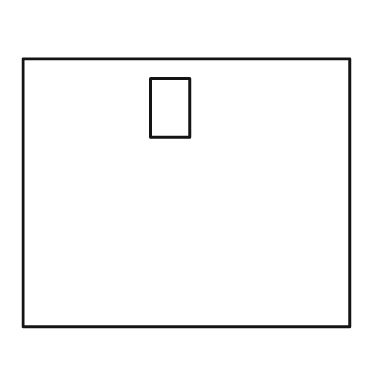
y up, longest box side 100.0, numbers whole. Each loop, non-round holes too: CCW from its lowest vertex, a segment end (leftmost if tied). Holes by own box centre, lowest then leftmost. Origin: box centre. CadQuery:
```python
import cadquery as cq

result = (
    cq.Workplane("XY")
    .moveTo(-50.0, -41.0)
    .lineTo(50.0, -41.0)
    .lineTo(50.0, 41.0)
    .lineTo(-50.0, 41.0)
    .close()
    .moveTo(-11.0, 17.0)
    .lineTo(1.0, 17.0)
    .lineTo(1.0, 35.0)
    .lineTo(-11.0, 35.0)
    .close()
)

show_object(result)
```